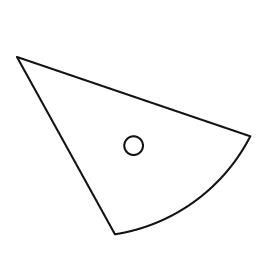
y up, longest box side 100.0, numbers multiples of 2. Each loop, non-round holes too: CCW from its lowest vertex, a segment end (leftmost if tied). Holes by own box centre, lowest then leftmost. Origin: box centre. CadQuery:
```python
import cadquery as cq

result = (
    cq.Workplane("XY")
    .moveTo(-8.0, -38.0)
    .threePointArc((26.0, -24.0), (50.0, 4.0))
    .lineTo(-50.0, 38.0)
    .close()
    .moveTo(0.0, 0.0)
    .circle(4.0)
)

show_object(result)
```